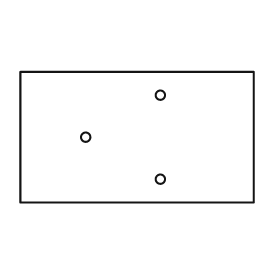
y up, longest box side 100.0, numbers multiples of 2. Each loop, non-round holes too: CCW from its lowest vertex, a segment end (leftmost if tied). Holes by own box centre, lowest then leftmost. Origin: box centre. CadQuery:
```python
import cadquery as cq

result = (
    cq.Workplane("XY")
    .moveTo(-50.0, -28.0)
    .lineTo(50.0, -28.0)
    .lineTo(50.0, 28.0)
    .lineTo(-50.0, 28.0)
    .close()
    .moveTo(10.0, -18.0)
    .circle(2.0)
    .moveTo(-22.0, 0.0)
    .circle(2.0)
    .moveTo(10.0, 18.0)
    .circle(2.0)
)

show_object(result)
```